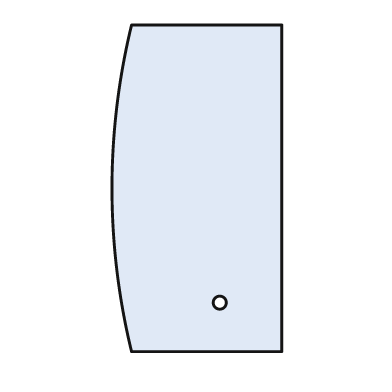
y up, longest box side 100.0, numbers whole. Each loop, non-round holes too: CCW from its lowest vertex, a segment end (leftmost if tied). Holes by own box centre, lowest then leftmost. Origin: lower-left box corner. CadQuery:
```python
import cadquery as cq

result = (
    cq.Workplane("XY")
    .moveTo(6.0, 0.0)
    .lineTo(52.0, 0.0)
    .lineTo(52.0, 100.0)
    .lineTo(6.0, 100.0)
    .threePointArc((0.0, 50.0), (6.0, 0.0))
    .close()
    .moveTo(33.0, 15.0)
    .circle(2.0)
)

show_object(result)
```